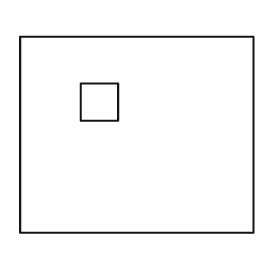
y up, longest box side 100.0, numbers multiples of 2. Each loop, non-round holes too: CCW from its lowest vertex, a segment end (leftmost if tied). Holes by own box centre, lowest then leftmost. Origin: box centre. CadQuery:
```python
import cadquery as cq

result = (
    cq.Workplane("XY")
    .moveTo(-50.0, -42.0)
    .lineTo(50.0, -42.0)
    .lineTo(50.0, 42.0)
    .lineTo(-50.0, 42.0)
    .close()
    .moveTo(-24.0, 6.0)
    .lineTo(-8.0, 6.0)
    .lineTo(-8.0, 22.0)
    .lineTo(-24.0, 22.0)
    .close()
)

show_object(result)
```